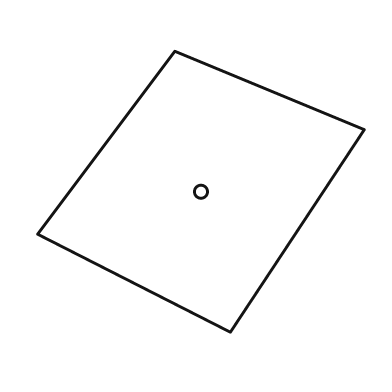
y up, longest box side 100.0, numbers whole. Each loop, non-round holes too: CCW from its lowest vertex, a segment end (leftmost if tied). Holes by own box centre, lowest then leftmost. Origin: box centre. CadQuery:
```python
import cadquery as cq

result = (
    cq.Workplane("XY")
    .moveTo(9.0, -43.0)
    .lineTo(50.0, 19.0)
    .lineTo(-8.0, 43.0)
    .lineTo(-50.0, -13.0)
    .close()
    .moveTo(0.0, 0.0)
    .circle(2.0)
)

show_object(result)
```